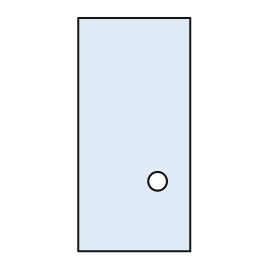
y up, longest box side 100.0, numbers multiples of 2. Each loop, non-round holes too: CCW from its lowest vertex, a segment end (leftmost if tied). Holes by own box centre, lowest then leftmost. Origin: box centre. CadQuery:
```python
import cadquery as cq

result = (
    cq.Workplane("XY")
    .moveTo(-24.0, -50.0)
    .lineTo(24.0, -50.0)
    .lineTo(24.0, 50.0)
    .lineTo(-24.0, 50.0)
    .close()
    .moveTo(10.0, -20.0)
    .circle(4.0)
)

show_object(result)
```